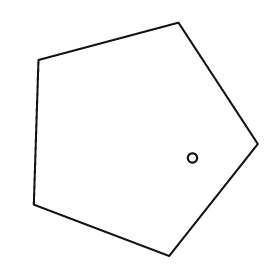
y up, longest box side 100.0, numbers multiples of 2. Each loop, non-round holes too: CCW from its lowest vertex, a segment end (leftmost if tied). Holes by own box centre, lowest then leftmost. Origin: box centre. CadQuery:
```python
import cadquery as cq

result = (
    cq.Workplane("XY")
    .moveTo(10.0, -50.0)
    .lineTo(48.0, -2.0)
    .lineTo(14.0, 50.0)
    .lineTo(-46.0, 34.0)
    .lineTo(-48.0, -28.0)
    .close()
    .moveTo(20.0, -8.0)
    .circle(2.0)
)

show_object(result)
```